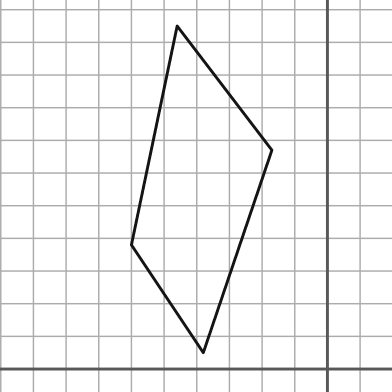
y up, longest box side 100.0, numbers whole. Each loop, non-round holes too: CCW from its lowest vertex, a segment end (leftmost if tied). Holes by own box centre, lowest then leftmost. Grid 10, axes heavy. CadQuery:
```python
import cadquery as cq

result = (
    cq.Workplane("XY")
    .moveTo(-38.0, 5.0)
    .lineTo(-17.0, 67.0)
    .lineTo(-46.0, 105.0)
    .lineTo(-60.0, 38.0)
    .close()
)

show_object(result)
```